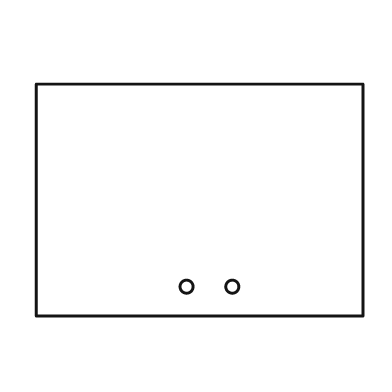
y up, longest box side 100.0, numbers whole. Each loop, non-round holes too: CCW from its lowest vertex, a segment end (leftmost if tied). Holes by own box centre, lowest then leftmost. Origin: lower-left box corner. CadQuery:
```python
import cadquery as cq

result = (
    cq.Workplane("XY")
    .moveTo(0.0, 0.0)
    .lineTo(100.0, 0.0)
    .lineTo(100.0, 71.0)
    .lineTo(0.0, 71.0)
    .close()
    .moveTo(46.0, 9.0)
    .circle(2.0)
    .moveTo(60.0, 9.0)
    .circle(2.0)
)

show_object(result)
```